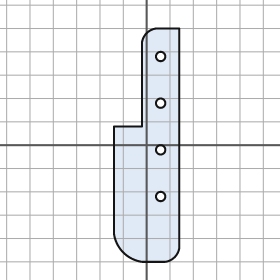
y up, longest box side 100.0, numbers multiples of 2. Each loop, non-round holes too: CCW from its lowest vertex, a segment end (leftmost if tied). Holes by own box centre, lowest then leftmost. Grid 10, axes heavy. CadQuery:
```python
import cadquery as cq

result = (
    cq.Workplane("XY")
    .moveTo(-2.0, -50.0)
    .lineTo(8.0, -50.0)
    .threePointArc((12.0, -48.0), (14.0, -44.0))
    .lineTo(14.0, 50.0)
    .lineTo(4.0, 50.0)
    .threePointArc((0.0, 48.0), (-2.0, 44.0))
    .lineTo(-2.0, 8.0)
    .lineTo(-14.0, 8.0)
    .lineTo(-14.0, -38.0)
    .threePointArc((-10.0, -46.0), (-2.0, -50.0))
    .close()
    .moveTo(6.0, -22.0)
    .circle(2.0)
    .moveTo(6.0, -2.0)
    .circle(2.0)
    .moveTo(6.0, 18.0)
    .circle(2.0)
    .moveTo(6.0, 38.0)
    .circle(2.0)
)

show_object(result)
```